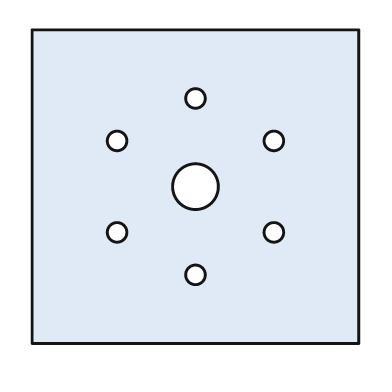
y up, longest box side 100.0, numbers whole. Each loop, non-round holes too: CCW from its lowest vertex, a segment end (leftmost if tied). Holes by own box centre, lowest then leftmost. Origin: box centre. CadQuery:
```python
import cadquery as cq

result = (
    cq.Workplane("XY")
    .moveTo(-50.0, -48.0)
    .lineTo(50.0, -48.0)
    .lineTo(50.0, 48.0)
    .lineTo(-50.0, 48.0)
    .close()
    .moveTo(0.0, -27.0)
    .circle(3.0)
    .moveTo(-24.0, -14.0)
    .circle(3.0)
    .moveTo(24.0, -14.0)
    .circle(3.0)
    .moveTo(0.0, 0.0)
    .circle(7.0)
    .moveTo(-24.0, 14.0)
    .circle(3.0)
    .moveTo(24.0, 14.0)
    .circle(3.0)
    .moveTo(0.0, 27.0)
    .circle(3.0)
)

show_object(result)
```